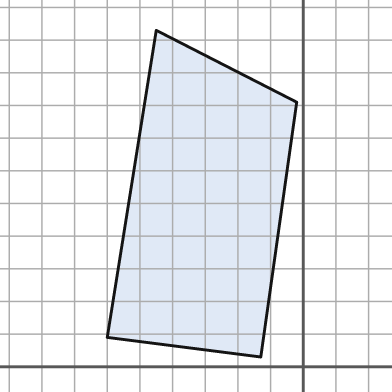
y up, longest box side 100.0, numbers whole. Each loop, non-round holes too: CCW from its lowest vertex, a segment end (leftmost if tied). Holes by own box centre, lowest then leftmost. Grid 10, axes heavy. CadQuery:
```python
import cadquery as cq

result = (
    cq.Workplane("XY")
    .moveTo(-13.0, 3.0)
    .lineTo(-2.0, 81.0)
    .lineTo(-45.0, 103.0)
    .lineTo(-60.0, 9.0)
    .close()
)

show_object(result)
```